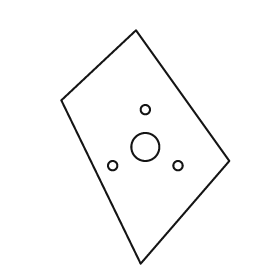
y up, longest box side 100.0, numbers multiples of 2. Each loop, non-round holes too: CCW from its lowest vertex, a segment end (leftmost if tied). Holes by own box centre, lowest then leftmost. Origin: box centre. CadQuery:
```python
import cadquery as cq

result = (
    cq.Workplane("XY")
    .moveTo(-2.0, -50.0)
    .lineTo(36.0, -6.0)
    .lineTo(-4.0, 50.0)
    .lineTo(-36.0, 20.0)
    .close()
    .moveTo(-14.0, -8.0)
    .circle(2.0)
    .moveTo(14.0, -8.0)
    .circle(2.0)
    .moveTo(0.0, 0.0)
    .circle(6.0)
    .moveTo(0.0, 16.0)
    .circle(2.0)
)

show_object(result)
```